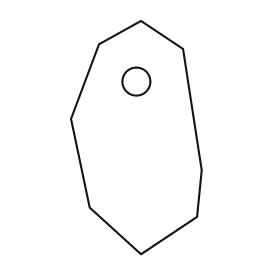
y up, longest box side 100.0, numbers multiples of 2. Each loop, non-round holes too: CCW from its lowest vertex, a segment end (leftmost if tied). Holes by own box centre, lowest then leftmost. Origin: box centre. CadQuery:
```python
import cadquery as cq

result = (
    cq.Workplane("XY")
    .moveTo(2.0, -50.0)
    .lineTo(26.0, -34.0)
    .lineTo(28.0, -14.0)
    .lineTo(20.0, 38.0)
    .lineTo(2.0, 50.0)
    .lineTo(-16.0, 40.0)
    .lineTo(-28.0, 8.0)
    .lineTo(-20.0, -30.0)
    .close()
    .moveTo(0.0, 24.0)
    .circle(6.0)
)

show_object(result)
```